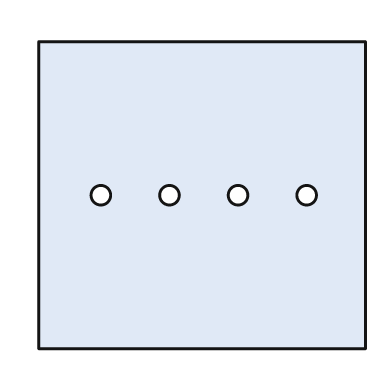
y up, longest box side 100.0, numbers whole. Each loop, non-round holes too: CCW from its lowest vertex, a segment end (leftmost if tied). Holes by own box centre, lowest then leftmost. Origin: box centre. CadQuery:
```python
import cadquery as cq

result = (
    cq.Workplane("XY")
    .moveTo(-50.0, -47.0)
    .lineTo(50.0, -47.0)
    .lineTo(50.0, 47.0)
    .lineTo(-50.0, 47.0)
    .close()
    .moveTo(-31.0, 0.0)
    .circle(3.0)
    .moveTo(-10.0, 0.0)
    .circle(3.0)
    .moveTo(11.0, 0.0)
    .circle(3.0)
    .moveTo(32.0, 0.0)
    .circle(3.0)
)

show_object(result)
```